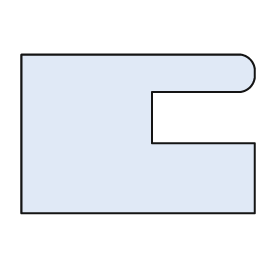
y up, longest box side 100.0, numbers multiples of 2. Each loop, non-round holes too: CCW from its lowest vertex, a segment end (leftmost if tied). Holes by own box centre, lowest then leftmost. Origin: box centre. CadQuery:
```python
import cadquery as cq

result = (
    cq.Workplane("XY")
    .moveTo(-50.0, -34.0)
    .lineTo(50.0, -34.0)
    .lineTo(50.0, -4.0)
    .lineTo(6.0, -4.0)
    .lineTo(6.0, 18.0)
    .lineTo(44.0, 18.0)
    .threePointArc((48.0, 20.0), (50.0, 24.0))
    .lineTo(50.0, 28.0)
    .threePointArc((48.0, 32.0), (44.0, 34.0))
    .lineTo(-50.0, 34.0)
    .close()
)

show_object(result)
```